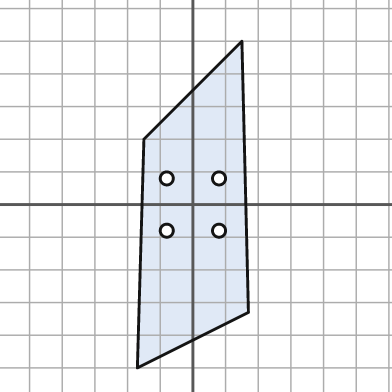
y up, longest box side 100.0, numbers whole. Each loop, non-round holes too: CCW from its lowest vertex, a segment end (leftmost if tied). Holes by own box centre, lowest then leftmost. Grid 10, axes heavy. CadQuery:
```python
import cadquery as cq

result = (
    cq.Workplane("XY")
    .moveTo(-17.0, -50.0)
    .lineTo(17.0, -33.0)
    .lineTo(15.0, 50.0)
    .lineTo(-15.0, 20.0)
    .close()
    .moveTo(-8.0, -8.0)
    .circle(2.0)
    .moveTo(8.0, -8.0)
    .circle(2.0)
    .moveTo(-8.0, 8.0)
    .circle(2.0)
    .moveTo(8.0, 8.0)
    .circle(2.0)
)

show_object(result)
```